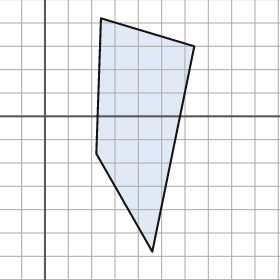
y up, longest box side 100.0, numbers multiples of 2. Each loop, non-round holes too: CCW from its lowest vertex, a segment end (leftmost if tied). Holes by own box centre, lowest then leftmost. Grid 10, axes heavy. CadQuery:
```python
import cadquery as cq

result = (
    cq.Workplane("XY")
    .moveTo(46.0, -58.0)
    .lineTo(64.0, 30.0)
    .lineTo(24.0, 42.0)
    .lineTo(22.0, -16.0)
    .close()
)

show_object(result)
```